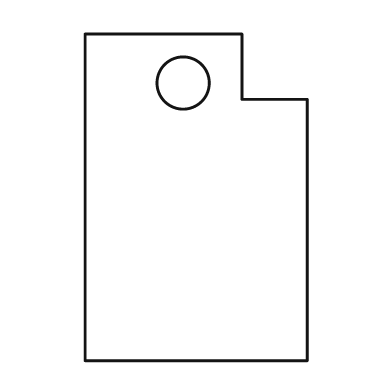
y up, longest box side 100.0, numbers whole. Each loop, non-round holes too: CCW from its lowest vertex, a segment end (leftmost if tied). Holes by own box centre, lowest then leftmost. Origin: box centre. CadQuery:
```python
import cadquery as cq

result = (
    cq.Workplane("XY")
    .moveTo(-34.0, -50.0)
    .lineTo(34.0, -50.0)
    .lineTo(34.0, 30.0)
    .lineTo(14.0, 30.0)
    .lineTo(14.0, 50.0)
    .lineTo(-34.0, 50.0)
    .close()
    .moveTo(-4.0, 35.0)
    .circle(8.0)
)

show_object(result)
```